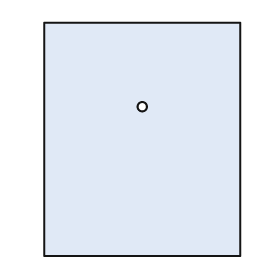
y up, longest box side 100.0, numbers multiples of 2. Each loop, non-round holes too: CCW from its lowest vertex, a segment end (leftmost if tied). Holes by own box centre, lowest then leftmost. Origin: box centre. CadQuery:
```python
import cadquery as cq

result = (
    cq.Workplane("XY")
    .moveTo(-42.0, -50.0)
    .lineTo(42.0, -50.0)
    .lineTo(42.0, 50.0)
    .lineTo(-42.0, 50.0)
    .close()
    .moveTo(0.0, 14.0)
    .circle(2.0)
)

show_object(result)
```